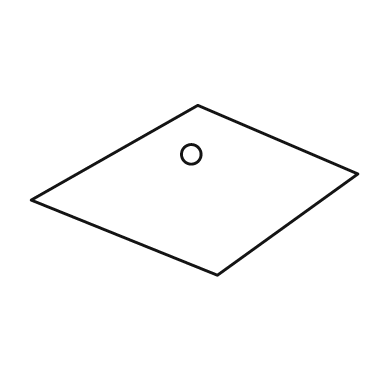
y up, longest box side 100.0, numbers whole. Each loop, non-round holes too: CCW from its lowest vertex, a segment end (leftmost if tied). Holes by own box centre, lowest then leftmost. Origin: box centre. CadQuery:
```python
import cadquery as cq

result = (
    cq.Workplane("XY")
    .moveTo(7.0, -26.0)
    .lineTo(50.0, 5.0)
    .lineTo(1.0, 26.0)
    .lineTo(-50.0, -3.0)
    .close()
    .moveTo(-1.0, 11.0)
    .circle(3.0)
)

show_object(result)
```